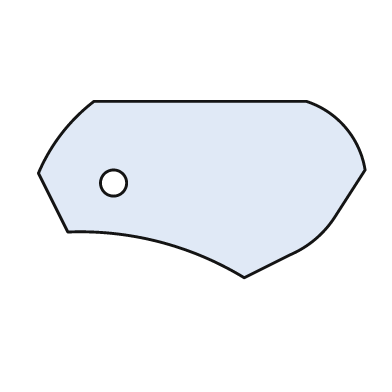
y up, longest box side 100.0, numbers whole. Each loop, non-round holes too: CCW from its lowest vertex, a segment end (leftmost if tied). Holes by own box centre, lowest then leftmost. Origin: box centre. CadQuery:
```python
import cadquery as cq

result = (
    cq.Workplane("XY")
    .moveTo(13.0, -27.0)
    .lineTo(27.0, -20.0)
    .threePointArc((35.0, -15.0), (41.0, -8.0))
    .lineTo(50.0, 6.0)
    .threePointArc((44.0, 19.0), (32.0, 27.0))
    .lineTo(-33.0, 27.0)
    .threePointArc((-43.0, 17.0), (-50.0, 5.0))
    .lineTo(-41.0, -13.0)
    .threePointArc((-13.0, -16.0), (13.0, -27.0))
    .close()
    .moveTo(-27.0, 2.0)
    .circle(4.0)
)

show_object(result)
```